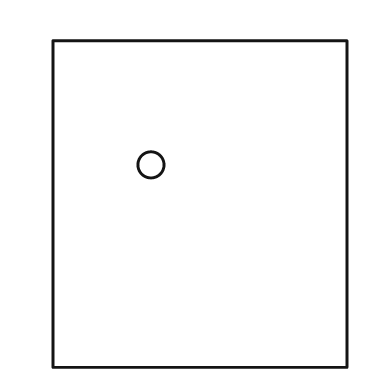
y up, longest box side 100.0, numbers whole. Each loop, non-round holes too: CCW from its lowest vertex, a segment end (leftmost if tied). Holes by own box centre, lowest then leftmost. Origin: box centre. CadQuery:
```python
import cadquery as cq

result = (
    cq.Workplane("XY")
    .moveTo(-45.0, -50.0)
    .lineTo(45.0, -50.0)
    .lineTo(45.0, 50.0)
    .lineTo(-45.0, 50.0)
    .close()
    .moveTo(-15.0, 12.0)
    .circle(4.0)
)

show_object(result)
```